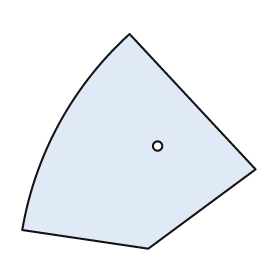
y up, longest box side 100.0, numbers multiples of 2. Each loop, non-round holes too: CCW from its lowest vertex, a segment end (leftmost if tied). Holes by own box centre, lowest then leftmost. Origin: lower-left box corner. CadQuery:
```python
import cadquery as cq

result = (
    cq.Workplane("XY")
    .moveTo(54.0, 0.0)
    .lineTo(100.0, 34.0)
    .lineTo(46.0, 92.0)
    .threePointArc((16.0, 54.0), (0.0, 8.0))
    .close()
    .moveTo(58.0, 44.0)
    .circle(2.0)
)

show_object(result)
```